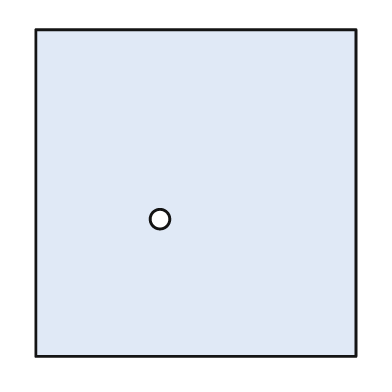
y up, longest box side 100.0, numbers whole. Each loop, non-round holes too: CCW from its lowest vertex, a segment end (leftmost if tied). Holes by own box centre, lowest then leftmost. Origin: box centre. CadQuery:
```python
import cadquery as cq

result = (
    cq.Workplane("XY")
    .moveTo(-49.0, -50.0)
    .lineTo(49.0, -50.0)
    .lineTo(49.0, 50.0)
    .lineTo(-49.0, 50.0)
    .close()
    .moveTo(-11.0, -8.0)
    .circle(3.0)
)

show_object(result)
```